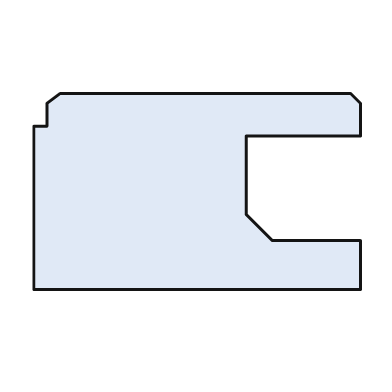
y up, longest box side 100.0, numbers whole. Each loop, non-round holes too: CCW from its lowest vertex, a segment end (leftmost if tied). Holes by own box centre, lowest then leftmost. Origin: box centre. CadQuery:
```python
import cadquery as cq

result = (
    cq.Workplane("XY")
    .moveTo(-50.0, -30.0)
    .lineTo(50.0, -30.0)
    .lineTo(50.0, -15.0)
    .lineTo(23.0, -15.0)
    .lineTo(15.0, -7.0)
    .lineTo(15.0, 17.0)
    .lineTo(50.0, 17.0)
    .lineTo(50.0, 27.0)
    .lineTo(47.0, 30.0)
    .lineTo(-42.0, 30.0)
    .lineTo(-46.0, 27.0)
    .lineTo(-46.0, 20.0)
    .lineTo(-50.0, 20.0)
    .close()
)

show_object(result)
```